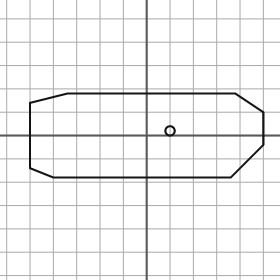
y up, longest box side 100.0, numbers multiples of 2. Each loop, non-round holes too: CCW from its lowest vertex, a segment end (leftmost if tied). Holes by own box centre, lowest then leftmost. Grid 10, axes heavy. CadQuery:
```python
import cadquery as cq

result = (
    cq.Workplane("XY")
    .moveTo(-40.0, -18.0)
    .lineTo(36.0, -18.0)
    .lineTo(50.0, -4.0)
    .lineTo(50.0, 10.0)
    .lineTo(38.0, 18.0)
    .lineTo(-34.0, 18.0)
    .lineTo(-50.0, 14.0)
    .lineTo(-50.0, -14.0)
    .close()
    .moveTo(10.0, 2.0)
    .circle(2.0)
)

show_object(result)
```